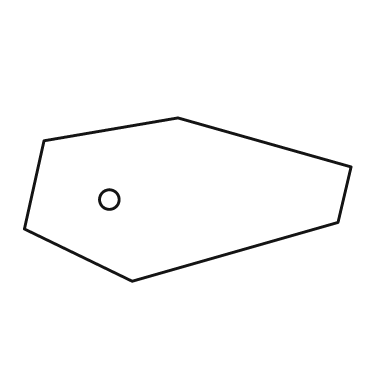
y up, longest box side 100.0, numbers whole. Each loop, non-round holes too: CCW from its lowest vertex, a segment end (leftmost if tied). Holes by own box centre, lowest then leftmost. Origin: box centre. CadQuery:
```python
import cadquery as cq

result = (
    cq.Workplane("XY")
    .moveTo(-17.0, -25.0)
    .lineTo(46.0, -7.0)
    .lineTo(50.0, 10.0)
    .lineTo(-3.0, 25.0)
    .lineTo(-44.0, 18.0)
    .lineTo(-50.0, -9.0)
    .close()
    .moveTo(-24.0, 0.0)
    .circle(3.0)
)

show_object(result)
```